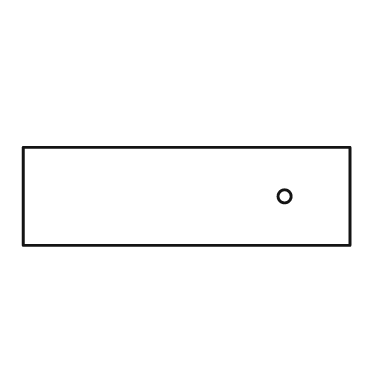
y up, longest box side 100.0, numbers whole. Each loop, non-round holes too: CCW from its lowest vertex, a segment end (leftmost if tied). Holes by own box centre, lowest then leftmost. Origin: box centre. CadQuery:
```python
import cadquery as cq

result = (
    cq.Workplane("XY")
    .moveTo(-50.0, -15.0)
    .lineTo(50.0, -15.0)
    .lineTo(50.0, 15.0)
    .lineTo(-50.0, 15.0)
    .close()
    .moveTo(30.0, 0.0)
    .circle(2.0)
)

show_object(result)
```